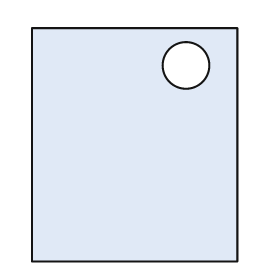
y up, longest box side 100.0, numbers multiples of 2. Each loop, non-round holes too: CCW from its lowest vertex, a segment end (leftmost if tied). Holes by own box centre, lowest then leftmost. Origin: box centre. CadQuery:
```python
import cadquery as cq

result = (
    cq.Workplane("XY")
    .moveTo(-44.0, -50.0)
    .lineTo(44.0, -50.0)
    .lineTo(44.0, 50.0)
    .lineTo(-44.0, 50.0)
    .close()
    .moveTo(22.0, 34.0)
    .circle(10.0)
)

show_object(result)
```